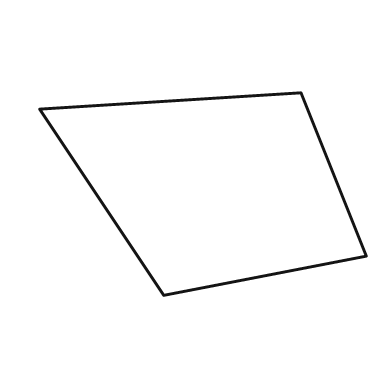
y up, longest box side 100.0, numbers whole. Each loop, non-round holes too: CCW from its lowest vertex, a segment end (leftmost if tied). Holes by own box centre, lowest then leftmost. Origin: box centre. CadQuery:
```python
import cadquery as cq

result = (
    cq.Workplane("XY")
    .moveTo(-12.0, -31.0)
    .lineTo(50.0, -19.0)
    .lineTo(30.0, 31.0)
    .lineTo(-50.0, 26.0)
    .close()
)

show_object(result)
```